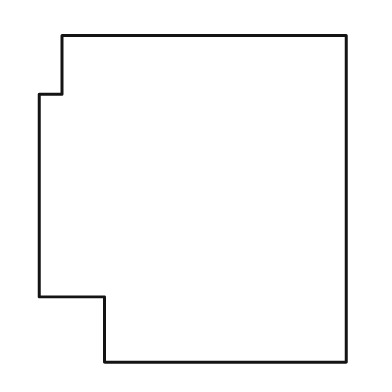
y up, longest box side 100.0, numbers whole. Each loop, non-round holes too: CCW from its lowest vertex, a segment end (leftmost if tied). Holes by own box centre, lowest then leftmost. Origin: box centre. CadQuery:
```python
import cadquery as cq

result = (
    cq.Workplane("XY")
    .moveTo(-27.0, -50.0)
    .lineTo(47.0, -50.0)
    .lineTo(47.0, 50.0)
    .lineTo(-40.0, 50.0)
    .lineTo(-40.0, 32.0)
    .lineTo(-47.0, 32.0)
    .lineTo(-47.0, -30.0)
    .lineTo(-27.0, -30.0)
    .close()
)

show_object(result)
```